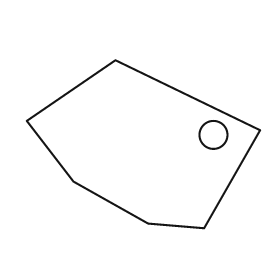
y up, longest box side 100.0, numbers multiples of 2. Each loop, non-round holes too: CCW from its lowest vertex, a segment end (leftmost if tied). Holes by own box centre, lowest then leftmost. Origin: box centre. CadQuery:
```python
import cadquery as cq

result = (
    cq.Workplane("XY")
    .moveTo(26.0, -36.0)
    .lineTo(50.0, 6.0)
    .lineTo(-12.0, 36.0)
    .lineTo(-50.0, 10.0)
    .lineTo(-30.0, -16.0)
    .lineTo(2.0, -34.0)
    .close()
    .moveTo(30.0, 4.0)
    .circle(6.0)
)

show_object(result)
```